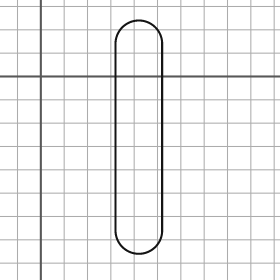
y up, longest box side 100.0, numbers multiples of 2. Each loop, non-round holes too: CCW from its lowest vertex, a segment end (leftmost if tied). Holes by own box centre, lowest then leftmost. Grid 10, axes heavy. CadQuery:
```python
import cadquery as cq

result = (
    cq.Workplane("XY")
    .moveTo(32.0, -66.0)
    .threePointArc((42.0, -76.0), (52.0, -66.0))
    .lineTo(52.0, 14.0)
    .threePointArc((42.0, 24.0), (32.0, 14.0))
    .close()
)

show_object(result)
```